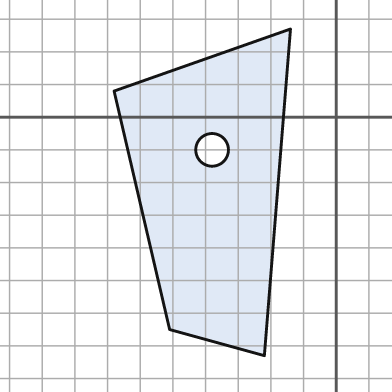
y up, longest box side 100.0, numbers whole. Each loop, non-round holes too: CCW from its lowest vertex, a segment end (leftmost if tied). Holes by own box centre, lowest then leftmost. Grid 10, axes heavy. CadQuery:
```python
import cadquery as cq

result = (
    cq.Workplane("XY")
    .moveTo(-22.0, -73.0)
    .lineTo(-14.0, 27.0)
    .lineTo(-68.0, 8.0)
    .lineTo(-51.0, -65.0)
    .close()
    .moveTo(-38.0, -10.0)
    .circle(5.0)
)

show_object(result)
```